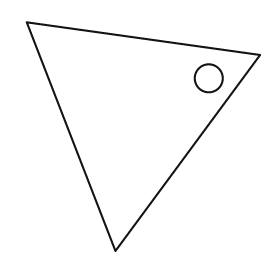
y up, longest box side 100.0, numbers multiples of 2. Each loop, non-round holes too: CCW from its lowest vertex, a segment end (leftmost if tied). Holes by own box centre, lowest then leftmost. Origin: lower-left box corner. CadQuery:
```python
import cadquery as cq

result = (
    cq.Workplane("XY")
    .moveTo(38.0, 0.0)
    .lineTo(100.0, 84.0)
    .lineTo(0.0, 98.0)
    .close()
    .moveTo(78.0, 74.0)
    .circle(6.0)
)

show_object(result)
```